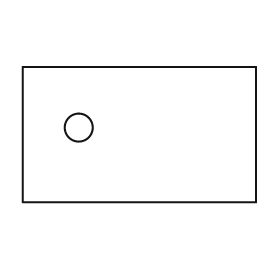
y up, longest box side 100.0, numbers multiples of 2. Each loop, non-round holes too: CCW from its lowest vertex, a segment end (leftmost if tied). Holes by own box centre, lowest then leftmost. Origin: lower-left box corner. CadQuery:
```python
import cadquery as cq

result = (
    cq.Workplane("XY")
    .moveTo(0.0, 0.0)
    .lineTo(100.0, 0.0)
    .lineTo(100.0, 58.0)
    .lineTo(0.0, 58.0)
    .close()
    .moveTo(24.0, 32.0)
    .circle(6.0)
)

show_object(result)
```